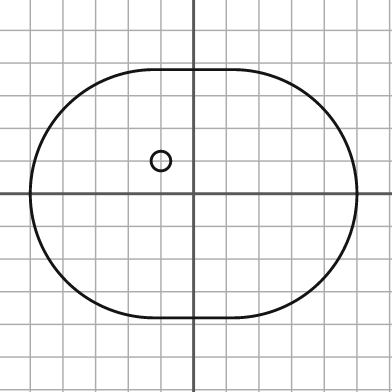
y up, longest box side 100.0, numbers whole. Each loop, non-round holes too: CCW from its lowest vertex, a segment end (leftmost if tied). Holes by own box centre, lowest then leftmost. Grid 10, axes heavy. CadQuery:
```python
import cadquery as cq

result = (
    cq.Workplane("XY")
    .moveTo(-12.0, -38.0)
    .lineTo(12.0, -38.0)
    .threePointArc((50.0, 0.0), (12.0, 38.0))
    .lineTo(-12.0, 38.0)
    .threePointArc((-50.0, 0.0), (-12.0, -38.0))
    .close()
    .moveTo(-10.0, 10.0)
    .circle(3.0)
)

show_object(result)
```